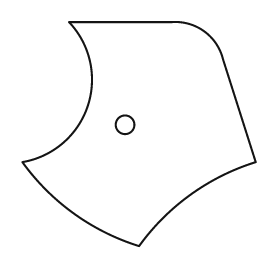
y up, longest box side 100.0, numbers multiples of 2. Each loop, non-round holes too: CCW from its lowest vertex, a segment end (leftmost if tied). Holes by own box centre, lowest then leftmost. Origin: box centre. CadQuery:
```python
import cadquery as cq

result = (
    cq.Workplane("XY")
    .moveTo(0.0, -48.0)
    .threePointArc((22.0, -26.0), (50.0, -12.0))
    .lineTo(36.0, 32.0)
    .threePointArc((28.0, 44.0), (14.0, 48.0))
    .lineTo(-30.0, 48.0)
    .threePointArc((-22.0, 12.0), (-50.0, -12.0))
    .threePointArc((-28.0, -34.0), (0.0, -48.0))
    .close()
    .moveTo(-6.0, 4.0)
    .circle(4.0)
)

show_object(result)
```